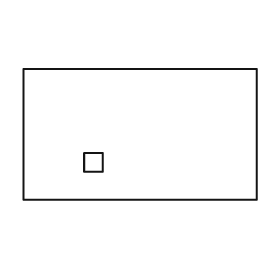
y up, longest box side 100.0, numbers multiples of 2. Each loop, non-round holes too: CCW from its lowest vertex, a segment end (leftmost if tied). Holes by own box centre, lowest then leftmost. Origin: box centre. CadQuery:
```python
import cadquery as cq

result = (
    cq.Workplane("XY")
    .moveTo(-50.0, -28.0)
    .lineTo(50.0, -28.0)
    .lineTo(50.0, 28.0)
    .lineTo(-50.0, 28.0)
    .close()
    .moveTo(-24.0, -16.0)
    .lineTo(-16.0, -16.0)
    .lineTo(-16.0, -8.0)
    .lineTo(-24.0, -8.0)
    .close()
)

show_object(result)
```